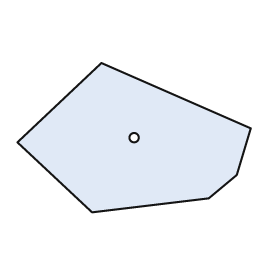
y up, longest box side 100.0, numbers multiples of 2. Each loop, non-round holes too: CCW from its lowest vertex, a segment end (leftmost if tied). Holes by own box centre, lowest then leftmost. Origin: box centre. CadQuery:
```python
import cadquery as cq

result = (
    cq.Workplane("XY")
    .moveTo(-18.0, -32.0)
    .lineTo(32.0, -26.0)
    .lineTo(44.0, -16.0)
    .lineTo(50.0, 4.0)
    .lineTo(-14.0, 32.0)
    .lineTo(-50.0, -2.0)
    .close()
    .moveTo(0.0, 0.0)
    .circle(2.0)
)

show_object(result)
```